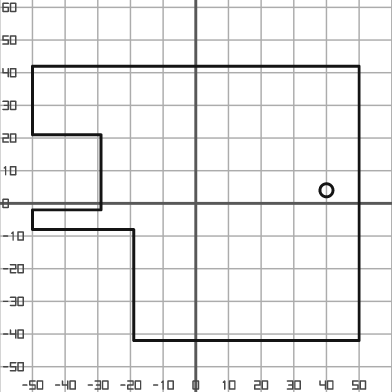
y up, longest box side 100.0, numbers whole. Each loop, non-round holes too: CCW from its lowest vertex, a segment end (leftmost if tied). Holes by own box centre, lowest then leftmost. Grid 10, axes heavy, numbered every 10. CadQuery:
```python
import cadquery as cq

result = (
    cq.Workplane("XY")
    .moveTo(-19.0, -42.0)
    .lineTo(50.0, -42.0)
    .lineTo(50.0, 42.0)
    .lineTo(-50.0, 42.0)
    .lineTo(-50.0, 21.0)
    .lineTo(-29.0, 21.0)
    .lineTo(-29.0, -2.0)
    .lineTo(-50.0, -2.0)
    .lineTo(-50.0, -8.0)
    .lineTo(-19.0, -8.0)
    .close()
    .moveTo(40.0, 4.0)
    .circle(2.0)
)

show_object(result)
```